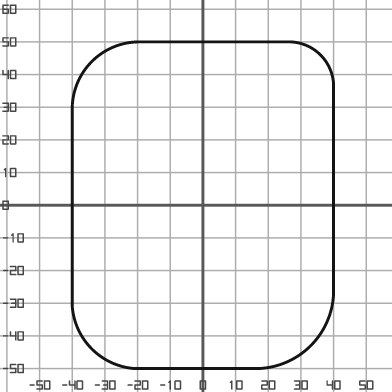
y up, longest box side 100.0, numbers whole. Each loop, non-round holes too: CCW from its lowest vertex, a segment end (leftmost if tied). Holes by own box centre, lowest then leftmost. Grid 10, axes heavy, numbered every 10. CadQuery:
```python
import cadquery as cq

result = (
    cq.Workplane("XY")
    .moveTo(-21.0, -50.0)
    .lineTo(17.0, -50.0)
    .threePointArc((33.0, -43.0), (40.0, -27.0))
    .lineTo(40.0, 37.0)
    .threePointArc((36.0, 46.0), (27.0, 50.0))
    .lineTo(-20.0, 50.0)
    .threePointArc((-34.0, 44.0), (-40.0, 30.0))
    .lineTo(-40.0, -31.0)
    .threePointArc((-34.0, -44.0), (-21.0, -50.0))
    .close()
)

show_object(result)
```